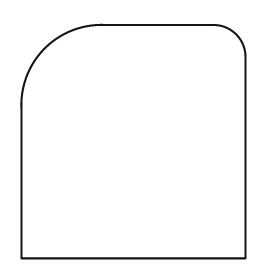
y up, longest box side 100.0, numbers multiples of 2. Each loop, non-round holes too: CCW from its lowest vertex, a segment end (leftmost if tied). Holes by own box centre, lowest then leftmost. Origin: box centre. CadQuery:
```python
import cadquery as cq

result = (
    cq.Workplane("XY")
    .moveTo(-48.0, -50.0)
    .lineTo(48.0, -50.0)
    .lineTo(48.0, 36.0)
    .threePointArc((44.0, 46.0), (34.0, 50.0))
    .lineTo(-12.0, 50.0)
    .threePointArc((-38.0, 40.0), (-48.0, 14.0))
    .close()
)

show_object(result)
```